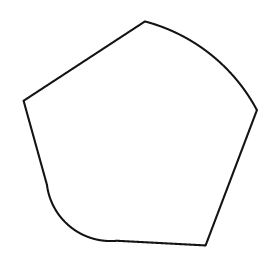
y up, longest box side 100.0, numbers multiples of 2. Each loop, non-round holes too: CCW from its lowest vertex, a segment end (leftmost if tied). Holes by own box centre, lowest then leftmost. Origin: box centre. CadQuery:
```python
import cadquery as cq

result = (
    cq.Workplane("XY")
    .moveTo(28.0, -48.0)
    .lineTo(50.0, 10.0)
    .threePointArc((30.0, 34.0), (2.0, 48.0))
    .lineTo(-50.0, 14.0)
    .lineTo(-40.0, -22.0)
    .threePointArc((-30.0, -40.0), (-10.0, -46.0))
    .close()
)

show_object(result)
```